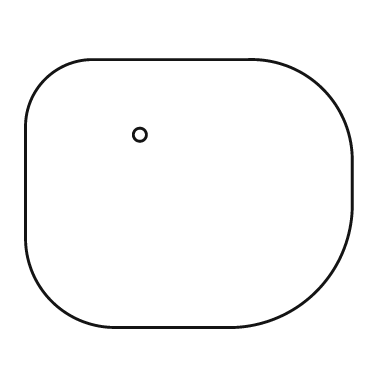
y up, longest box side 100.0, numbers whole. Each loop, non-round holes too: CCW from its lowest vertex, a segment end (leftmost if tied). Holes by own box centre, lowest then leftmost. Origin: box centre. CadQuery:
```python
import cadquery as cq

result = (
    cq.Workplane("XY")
    .moveTo(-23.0, -41.0)
    .lineTo(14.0, -41.0)
    .threePointArc((39.0, -30.0), (50.0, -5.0))
    .lineTo(50.0, 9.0)
    .threePointArc((41.0, 32.0), (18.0, 41.0))
    .lineTo(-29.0, 41.0)
    .threePointArc((-44.0, 35.0), (-50.0, 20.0))
    .lineTo(-50.0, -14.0)
    .threePointArc((-42.0, -33.0), (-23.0, -41.0))
    .close()
    .moveTo(-15.0, 18.0)
    .circle(2.0)
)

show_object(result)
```